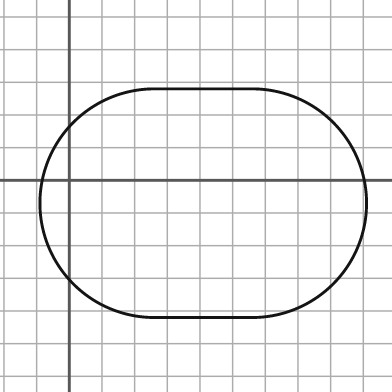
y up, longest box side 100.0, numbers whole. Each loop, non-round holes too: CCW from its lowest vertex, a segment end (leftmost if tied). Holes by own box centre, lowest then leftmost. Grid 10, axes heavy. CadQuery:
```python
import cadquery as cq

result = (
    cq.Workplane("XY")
    .moveTo(26.0, -42.0)
    .lineTo(56.0, -42.0)
    .threePointArc((91.0, -7.0), (56.0, 28.0))
    .lineTo(26.0, 28.0)
    .threePointArc((-9.0, -7.0), (26.0, -42.0))
    .close()
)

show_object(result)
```